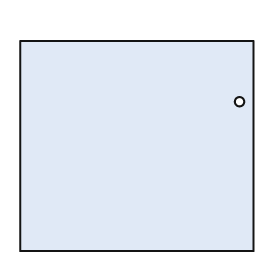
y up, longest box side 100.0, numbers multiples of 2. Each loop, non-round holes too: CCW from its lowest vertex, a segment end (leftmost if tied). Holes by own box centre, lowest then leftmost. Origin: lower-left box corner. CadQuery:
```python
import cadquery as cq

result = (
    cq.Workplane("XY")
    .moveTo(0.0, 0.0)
    .lineTo(100.0, 0.0)
    .lineTo(100.0, 90.0)
    .lineTo(0.0, 90.0)
    .close()
    .moveTo(94.0, 64.0)
    .circle(2.0)
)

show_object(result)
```